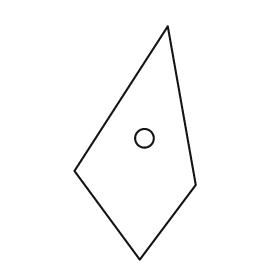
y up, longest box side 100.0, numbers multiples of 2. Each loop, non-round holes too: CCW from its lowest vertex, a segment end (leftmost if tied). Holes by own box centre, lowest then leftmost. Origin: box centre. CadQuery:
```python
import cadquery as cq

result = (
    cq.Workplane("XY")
    .moveTo(2.0, -50.0)
    .lineTo(26.0, -18.0)
    .lineTo(14.0, 50.0)
    .lineTo(-26.0, -12.0)
    .close()
    .moveTo(4.0, 2.0)
    .circle(4.0)
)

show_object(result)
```